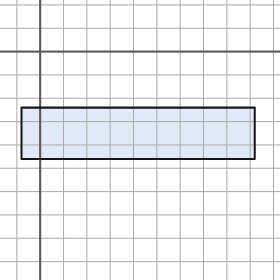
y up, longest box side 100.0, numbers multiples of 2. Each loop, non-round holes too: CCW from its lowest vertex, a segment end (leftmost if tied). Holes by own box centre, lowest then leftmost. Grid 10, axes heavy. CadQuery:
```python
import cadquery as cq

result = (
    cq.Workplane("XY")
    .moveTo(-8.0, -46.0)
    .lineTo(92.0, -46.0)
    .lineTo(92.0, -24.0)
    .lineTo(-8.0, -24.0)
    .close()
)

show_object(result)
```